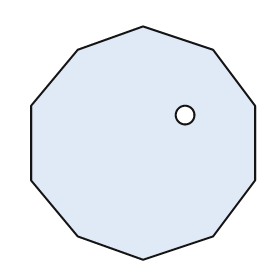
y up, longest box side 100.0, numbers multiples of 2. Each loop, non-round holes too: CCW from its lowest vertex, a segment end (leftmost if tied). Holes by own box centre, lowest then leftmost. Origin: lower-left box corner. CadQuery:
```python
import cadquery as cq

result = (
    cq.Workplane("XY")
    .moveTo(48.0, 0.0)
    .lineTo(78.0, 10.0)
    .lineTo(96.0, 34.0)
    .lineTo(96.0, 66.0)
    .lineTo(78.0, 90.0)
    .lineTo(48.0, 100.0)
    .lineTo(20.0, 90.0)
    .lineTo(0.0, 66.0)
    .lineTo(0.0, 34.0)
    .lineTo(20.0, 10.0)
    .close()
    .moveTo(66.0, 62.0)
    .circle(4.0)
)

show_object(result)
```